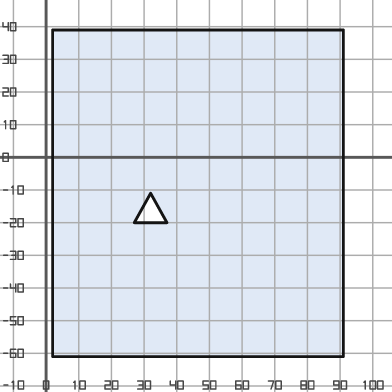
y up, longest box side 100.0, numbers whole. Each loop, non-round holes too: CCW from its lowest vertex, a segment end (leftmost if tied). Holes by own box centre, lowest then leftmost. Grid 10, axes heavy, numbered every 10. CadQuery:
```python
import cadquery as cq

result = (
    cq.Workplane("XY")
    .moveTo(2.0, -61.0)
    .lineTo(91.0, -61.0)
    .lineTo(91.0, 39.0)
    .lineTo(2.0, 39.0)
    .close()
    .moveTo(27.0, -20.0)
    .lineTo(37.0, -20.0)
    .lineTo(32.0, -11.0)
    .close()
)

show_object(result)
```